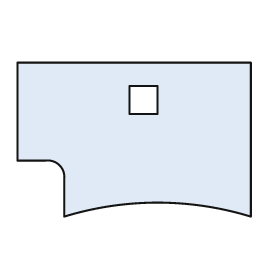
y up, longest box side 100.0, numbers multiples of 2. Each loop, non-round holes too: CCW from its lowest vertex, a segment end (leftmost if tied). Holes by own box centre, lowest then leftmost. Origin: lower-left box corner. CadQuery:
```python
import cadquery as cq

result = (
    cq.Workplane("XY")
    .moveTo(20.0, 0.0)
    .threePointArc((60.0, 6.0), (100.0, 0.0))
    .lineTo(100.0, 66.0)
    .lineTo(0.0, 66.0)
    .lineTo(0.0, 24.0)
    .lineTo(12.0, 24.0)
    .threePointArc((18.0, 22.0), (20.0, 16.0))
    .close()
    .moveTo(48.0, 44.0)
    .lineTo(60.0, 44.0)
    .lineTo(60.0, 56.0)
    .lineTo(48.0, 56.0)
    .close()
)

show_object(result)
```